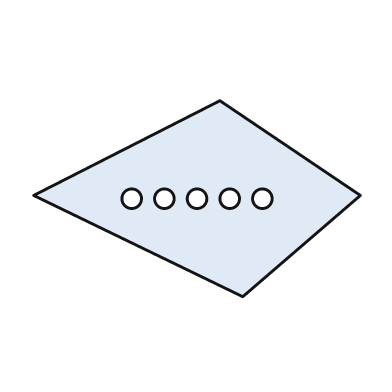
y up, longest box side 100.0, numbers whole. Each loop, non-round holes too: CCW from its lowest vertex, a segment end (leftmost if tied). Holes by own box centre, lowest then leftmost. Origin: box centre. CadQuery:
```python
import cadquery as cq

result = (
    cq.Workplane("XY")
    .moveTo(14.0, -30.0)
    .lineTo(50.0, 1.0)
    .lineTo(7.0, 30.0)
    .lineTo(-50.0, 1.0)
    .close()
    .moveTo(-20.0, 0.0)
    .circle(3.0)
    .moveTo(-10.0, 0.0)
    .circle(3.0)
    .moveTo(0.0, 0.0)
    .circle(3.0)
    .moveTo(10.0, 0.0)
    .circle(3.0)
    .moveTo(20.0, 0.0)
    .circle(3.0)
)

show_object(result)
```